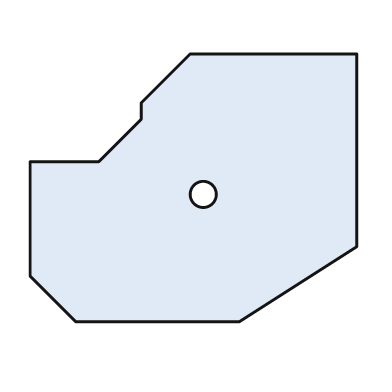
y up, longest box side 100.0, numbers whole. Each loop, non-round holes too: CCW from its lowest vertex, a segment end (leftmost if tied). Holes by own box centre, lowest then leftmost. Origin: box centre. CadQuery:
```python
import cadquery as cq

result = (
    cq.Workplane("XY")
    .moveTo(-36.0, -41.0)
    .lineTo(14.0, -41.0)
    .lineTo(50.0, -18.0)
    .lineTo(50.0, 41.0)
    .lineTo(-1.0, 41.0)
    .lineTo(-16.0, 26.0)
    .lineTo(-16.0, 21.0)
    .lineTo(-29.0, 8.0)
    .lineTo(-50.0, 8.0)
    .lineTo(-50.0, -27.0)
    .close()
    .moveTo(3.0, -2.0)
    .circle(4.0)
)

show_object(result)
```